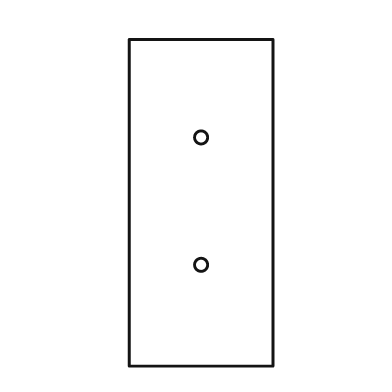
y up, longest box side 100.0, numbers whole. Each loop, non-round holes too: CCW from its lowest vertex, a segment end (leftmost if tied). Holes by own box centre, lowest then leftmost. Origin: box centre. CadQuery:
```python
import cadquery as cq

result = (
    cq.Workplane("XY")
    .moveTo(-22.0, -50.0)
    .lineTo(22.0, -50.0)
    .lineTo(22.0, 50.0)
    .lineTo(-22.0, 50.0)
    .close()
    .moveTo(0.0, -19.0)
    .circle(2.0)
    .moveTo(0.0, 20.0)
    .circle(2.0)
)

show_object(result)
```